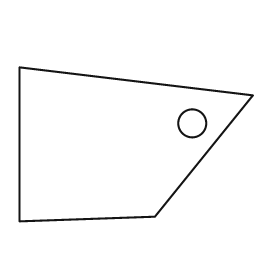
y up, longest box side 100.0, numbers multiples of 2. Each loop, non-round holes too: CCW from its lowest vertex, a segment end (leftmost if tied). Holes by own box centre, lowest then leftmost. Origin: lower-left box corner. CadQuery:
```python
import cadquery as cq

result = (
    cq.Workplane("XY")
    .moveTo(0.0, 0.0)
    .lineTo(58.0, 2.0)
    .lineTo(100.0, 54.0)
    .lineTo(0.0, 66.0)
    .close()
    .moveTo(74.0, 42.0)
    .circle(6.0)
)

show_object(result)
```